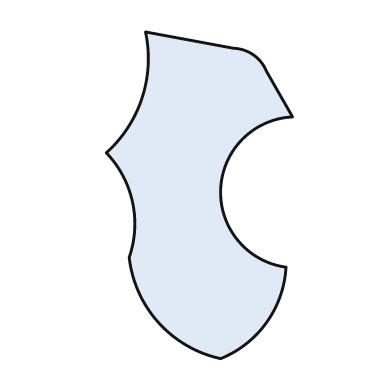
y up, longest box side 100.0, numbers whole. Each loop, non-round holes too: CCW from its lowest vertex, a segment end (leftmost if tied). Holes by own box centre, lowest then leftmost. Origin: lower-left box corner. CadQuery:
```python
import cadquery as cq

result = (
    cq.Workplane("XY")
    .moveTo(35.0, 0.0)
    .threePointArc((49.0, 11.0), (55.0, 28.0))
    .threePointArc((35.0, 52.0), (57.0, 74.0))
    .lineTo(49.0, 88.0)
    .threePointArc((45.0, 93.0), (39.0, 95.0))
    .lineTo(12.0, 100.0)
    .threePointArc((11.0, 80.0), (0.0, 63.0))
    .threePointArc((8.0, 48.0), (7.0, 31.0))
    .threePointArc((16.0, 11.0), (35.0, 0.0))
    .close()
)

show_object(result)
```